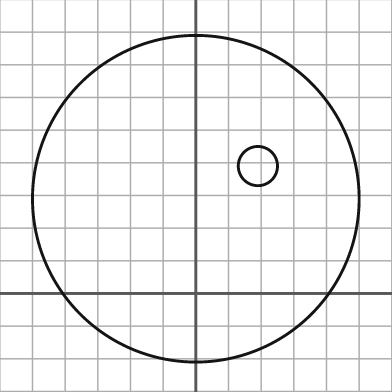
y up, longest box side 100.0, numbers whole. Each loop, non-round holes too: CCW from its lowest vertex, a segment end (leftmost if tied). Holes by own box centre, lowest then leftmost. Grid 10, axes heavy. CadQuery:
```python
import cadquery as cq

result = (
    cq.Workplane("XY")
    .moveTo(0.0, 29.0)
    .circle(50.0)
    .moveTo(19.0, 39.0)
    .circle(6.0)
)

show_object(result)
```